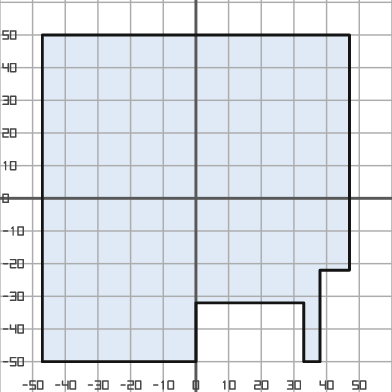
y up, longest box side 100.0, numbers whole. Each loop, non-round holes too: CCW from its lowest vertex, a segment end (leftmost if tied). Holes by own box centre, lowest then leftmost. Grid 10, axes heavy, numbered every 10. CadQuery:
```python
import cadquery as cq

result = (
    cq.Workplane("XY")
    .moveTo(-47.0, -50.0)
    .lineTo(0.0, -50.0)
    .lineTo(0.0, -32.0)
    .lineTo(33.0, -32.0)
    .lineTo(33.0, -50.0)
    .lineTo(38.0, -50.0)
    .lineTo(38.0, -22.0)
    .lineTo(47.0, -22.0)
    .lineTo(47.0, 50.0)
    .lineTo(-47.0, 50.0)
    .close()
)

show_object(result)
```